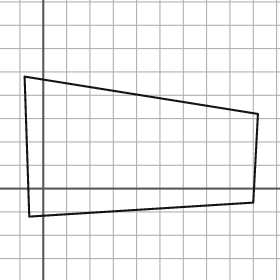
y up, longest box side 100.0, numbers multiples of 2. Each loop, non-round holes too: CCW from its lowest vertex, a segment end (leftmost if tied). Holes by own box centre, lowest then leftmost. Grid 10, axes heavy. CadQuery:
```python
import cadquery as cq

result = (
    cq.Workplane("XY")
    .moveTo(-6.0, -12.0)
    .lineTo(90.0, -6.0)
    .lineTo(92.0, 32.0)
    .lineTo(-8.0, 48.0)
    .close()
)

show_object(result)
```